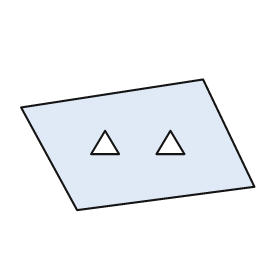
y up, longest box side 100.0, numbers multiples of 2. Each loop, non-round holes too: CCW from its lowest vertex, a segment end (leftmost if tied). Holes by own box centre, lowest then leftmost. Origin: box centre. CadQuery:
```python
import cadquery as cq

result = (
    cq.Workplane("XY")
    .moveTo(-26.0, -28.0)
    .lineTo(50.0, -18.0)
    .lineTo(28.0, 28.0)
    .lineTo(-50.0, 16.0)
    .close()
    .moveTo(-20.0, -4.0)
    .lineTo(-8.0, -4.0)
    .lineTo(-14.0, 6.0)
    .close()
    .moveTo(8.0, -4.0)
    .lineTo(20.0, -4.0)
    .lineTo(14.0, 6.0)
    .close()
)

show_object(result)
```